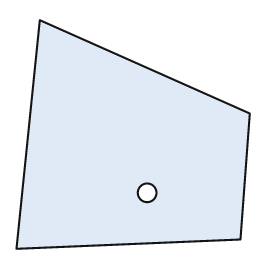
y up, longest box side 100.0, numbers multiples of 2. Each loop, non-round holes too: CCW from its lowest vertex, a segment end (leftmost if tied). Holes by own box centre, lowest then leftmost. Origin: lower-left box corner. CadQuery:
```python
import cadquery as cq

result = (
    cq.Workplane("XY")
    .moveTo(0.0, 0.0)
    .lineTo(96.0, 4.0)
    .lineTo(100.0, 58.0)
    .lineTo(10.0, 98.0)
    .close()
    .moveTo(56.0, 24.0)
    .circle(4.0)
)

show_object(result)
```